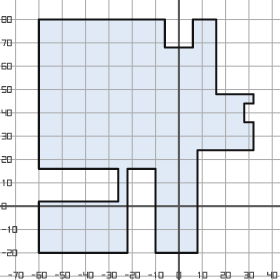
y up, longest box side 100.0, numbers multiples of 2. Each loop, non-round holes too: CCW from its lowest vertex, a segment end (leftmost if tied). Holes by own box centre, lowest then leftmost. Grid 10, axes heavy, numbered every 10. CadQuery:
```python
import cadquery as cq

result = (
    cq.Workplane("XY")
    .moveTo(-60.0, -20.0)
    .lineTo(-22.0, -20.0)
    .lineTo(-22.0, 16.0)
    .lineTo(-10.0, 16.0)
    .lineTo(-10.0, -20.0)
    .lineTo(8.0, -20.0)
    .lineTo(8.0, 24.0)
    .lineTo(32.0, 24.0)
    .lineTo(32.0, 36.0)
    .lineTo(28.0, 36.0)
    .lineTo(28.0, 44.0)
    .lineTo(32.0, 44.0)
    .lineTo(32.0, 48.0)
    .lineTo(16.0, 48.0)
    .lineTo(16.0, 80.0)
    .lineTo(6.0, 80.0)
    .lineTo(6.0, 68.0)
    .lineTo(-6.0, 68.0)
    .lineTo(-6.0, 80.0)
    .lineTo(-60.0, 80.0)
    .lineTo(-60.0, 16.0)
    .lineTo(-26.0, 16.0)
    .lineTo(-26.0, 2.0)
    .lineTo(-60.0, 2.0)
    .close()
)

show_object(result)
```